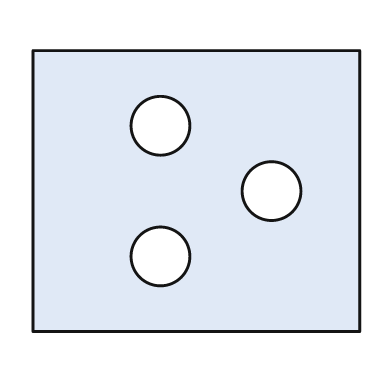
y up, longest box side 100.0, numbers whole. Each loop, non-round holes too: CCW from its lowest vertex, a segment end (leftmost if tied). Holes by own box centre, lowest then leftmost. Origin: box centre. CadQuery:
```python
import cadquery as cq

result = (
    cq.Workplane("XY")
    .moveTo(-50.0, -43.0)
    .lineTo(50.0, -43.0)
    .lineTo(50.0, 43.0)
    .lineTo(-50.0, 43.0)
    .close()
    .moveTo(-11.0, -20.0)
    .circle(9.0)
    .moveTo(23.0, 0.0)
    .circle(9.0)
    .moveTo(-11.0, 20.0)
    .circle(9.0)
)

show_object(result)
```